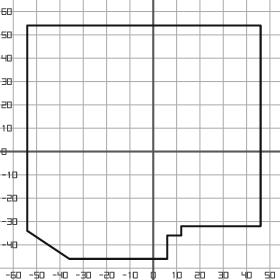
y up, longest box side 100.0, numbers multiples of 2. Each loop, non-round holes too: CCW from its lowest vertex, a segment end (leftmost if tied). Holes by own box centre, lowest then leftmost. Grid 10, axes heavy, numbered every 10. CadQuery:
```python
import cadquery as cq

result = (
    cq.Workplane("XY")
    .moveTo(-36.0, -46.0)
    .lineTo(6.0, -46.0)
    .lineTo(6.0, -36.0)
    .lineTo(12.0, -36.0)
    .lineTo(12.0, -32.0)
    .lineTo(46.0, -32.0)
    .lineTo(46.0, 54.0)
    .lineTo(-54.0, 54.0)
    .lineTo(-54.0, -34.0)
    .close()
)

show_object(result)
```